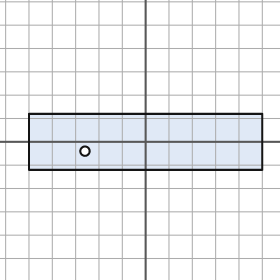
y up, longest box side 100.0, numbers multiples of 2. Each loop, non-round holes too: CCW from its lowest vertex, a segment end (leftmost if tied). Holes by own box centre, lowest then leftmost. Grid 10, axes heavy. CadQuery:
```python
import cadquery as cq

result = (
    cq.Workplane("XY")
    .moveTo(-50.0, -12.0)
    .lineTo(50.0, -12.0)
    .lineTo(50.0, 12.0)
    .lineTo(-50.0, 12.0)
    .close()
    .moveTo(-26.0, -4.0)
    .circle(2.0)
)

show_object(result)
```